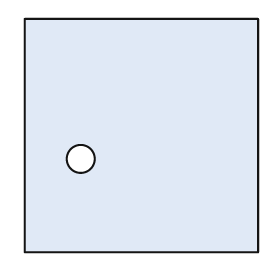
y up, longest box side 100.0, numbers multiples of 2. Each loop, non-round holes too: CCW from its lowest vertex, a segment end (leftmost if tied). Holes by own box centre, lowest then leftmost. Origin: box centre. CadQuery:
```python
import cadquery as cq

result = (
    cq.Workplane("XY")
    .moveTo(-50.0, -50.0)
    .lineTo(50.0, -50.0)
    .lineTo(50.0, 50.0)
    .lineTo(-50.0, 50.0)
    .close()
    .moveTo(-26.0, -10.0)
    .circle(6.0)
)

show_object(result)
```